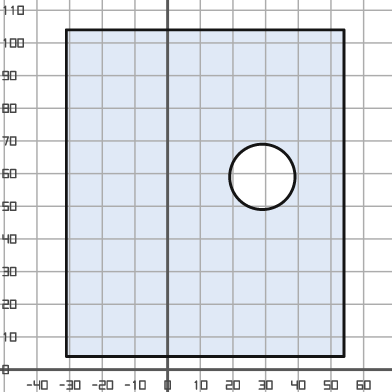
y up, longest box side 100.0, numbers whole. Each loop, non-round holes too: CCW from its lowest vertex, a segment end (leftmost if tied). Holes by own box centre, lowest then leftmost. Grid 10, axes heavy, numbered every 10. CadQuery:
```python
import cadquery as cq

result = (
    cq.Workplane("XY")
    .moveTo(-31.0, 4.0)
    .lineTo(54.0, 4.0)
    .lineTo(54.0, 104.0)
    .lineTo(-31.0, 104.0)
    .close()
    .moveTo(29.0, 59.0)
    .circle(10.0)
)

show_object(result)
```